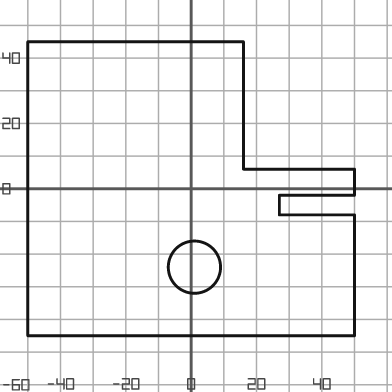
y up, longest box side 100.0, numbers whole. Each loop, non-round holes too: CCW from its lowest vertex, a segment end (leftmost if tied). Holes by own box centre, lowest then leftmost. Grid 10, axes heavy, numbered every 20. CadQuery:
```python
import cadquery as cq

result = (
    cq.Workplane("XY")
    .moveTo(-50.0, -45.0)
    .lineTo(50.0, -45.0)
    .lineTo(50.0, -8.0)
    .lineTo(27.0, -8.0)
    .lineTo(27.0, -2.0)
    .lineTo(50.0, -2.0)
    .lineTo(50.0, 6.0)
    .lineTo(16.0, 6.0)
    .lineTo(16.0, 45.0)
    .lineTo(-50.0, 45.0)
    .close()
    .moveTo(1.0, -24.0)
    .circle(8.0)
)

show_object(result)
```